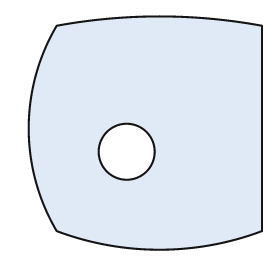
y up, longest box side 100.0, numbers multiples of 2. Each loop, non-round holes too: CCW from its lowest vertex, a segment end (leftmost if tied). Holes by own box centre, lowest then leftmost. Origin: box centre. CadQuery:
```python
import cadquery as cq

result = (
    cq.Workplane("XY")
    .moveTo(-38.0, -42.0)
    .threePointArc((6.0, -50.0), (50.0, -42.0))
    .lineTo(50.0, 46.0)
    .threePointArc((6.0, 50.0), (-38.0, 46.0))
    .threePointArc((-50.0, 2.0), (-38.0, -42.0))
    .close()
    .moveTo(-8.0, -8.0)
    .circle(12.0)
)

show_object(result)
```